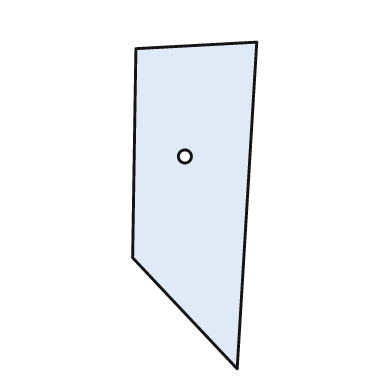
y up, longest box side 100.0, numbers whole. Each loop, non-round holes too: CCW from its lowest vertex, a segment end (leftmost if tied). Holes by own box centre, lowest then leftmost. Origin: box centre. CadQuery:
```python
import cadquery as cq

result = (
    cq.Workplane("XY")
    .moveTo(13.0, -50.0)
    .lineTo(19.0, 50.0)
    .lineTo(-18.0, 48.0)
    .lineTo(-19.0, -16.0)
    .close()
    .moveTo(-3.0, 15.0)
    .circle(2.0)
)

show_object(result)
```